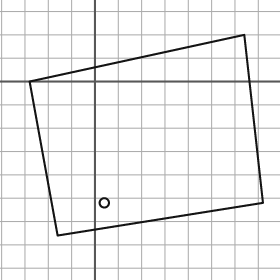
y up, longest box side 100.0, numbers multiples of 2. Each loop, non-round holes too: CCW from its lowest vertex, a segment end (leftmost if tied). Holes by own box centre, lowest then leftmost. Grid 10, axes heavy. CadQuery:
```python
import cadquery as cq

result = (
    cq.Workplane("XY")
    .moveTo(-16.0, -66.0)
    .lineTo(72.0, -52.0)
    .lineTo(64.0, 20.0)
    .lineTo(-28.0, 0.0)
    .close()
    .moveTo(4.0, -52.0)
    .circle(2.0)
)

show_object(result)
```